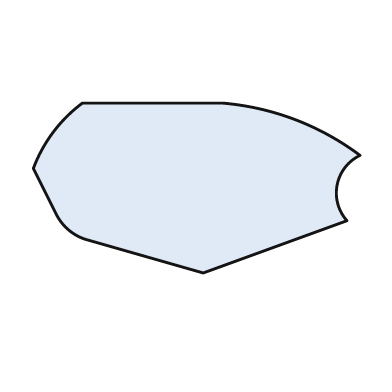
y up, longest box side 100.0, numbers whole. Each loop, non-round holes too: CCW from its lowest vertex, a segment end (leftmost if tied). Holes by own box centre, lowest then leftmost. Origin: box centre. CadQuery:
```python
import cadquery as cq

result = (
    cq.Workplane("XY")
    .moveTo(2.0, -26.0)
    .lineTo(46.0, -10.0)
    .threePointArc((43.0, 1.0), (50.0, 10.0))
    .threePointArc((30.0, 21.0), (8.0, 26.0))
    .lineTo(-35.0, 26.0)
    .threePointArc((-44.0, 17.0), (-50.0, 6.0))
    .lineTo(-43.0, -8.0)
    .threePointArc((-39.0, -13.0), (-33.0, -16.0))
    .close()
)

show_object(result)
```